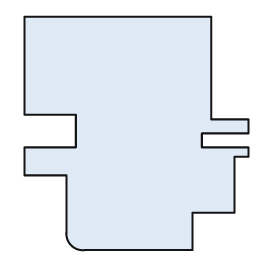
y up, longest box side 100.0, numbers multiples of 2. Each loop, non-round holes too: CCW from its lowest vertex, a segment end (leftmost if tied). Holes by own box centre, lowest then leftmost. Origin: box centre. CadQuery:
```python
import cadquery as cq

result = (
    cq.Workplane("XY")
    .moveTo(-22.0, -50.0)
    .lineTo(24.0, -50.0)
    .lineTo(24.0, -34.0)
    .lineTo(42.0, -34.0)
    .lineTo(42.0, -10.0)
    .lineTo(48.0, -10.0)
    .lineTo(48.0, -6.0)
    .lineTo(28.0, -6.0)
    .lineTo(28.0, 0.0)
    .lineTo(48.0, 0.0)
    .lineTo(48.0, 6.0)
    .lineTo(32.0, 6.0)
    .lineTo(32.0, 50.0)
    .lineTo(-48.0, 50.0)
    .lineTo(-48.0, 8.0)
    .lineTo(-26.0, 8.0)
    .lineTo(-26.0, -6.0)
    .lineTo(-48.0, -6.0)
    .lineTo(-48.0, -18.0)
    .lineTo(-30.0, -18.0)
    .lineTo(-30.0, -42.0)
    .threePointArc((-28.0, -48.0), (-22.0, -50.0))
    .close()
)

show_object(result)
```